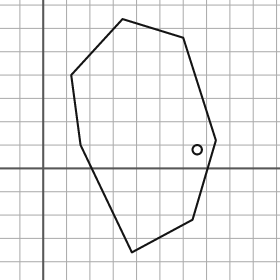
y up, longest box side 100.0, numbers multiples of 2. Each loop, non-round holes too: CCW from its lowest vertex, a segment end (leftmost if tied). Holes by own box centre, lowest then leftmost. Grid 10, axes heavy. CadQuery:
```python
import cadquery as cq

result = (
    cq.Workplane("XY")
    .moveTo(38.0, -36.0)
    .lineTo(64.0, -22.0)
    .lineTo(74.0, 12.0)
    .lineTo(60.0, 56.0)
    .lineTo(34.0, 64.0)
    .lineTo(12.0, 40.0)
    .lineTo(16.0, 10.0)
    .close()
    .moveTo(66.0, 8.0)
    .circle(2.0)
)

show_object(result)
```